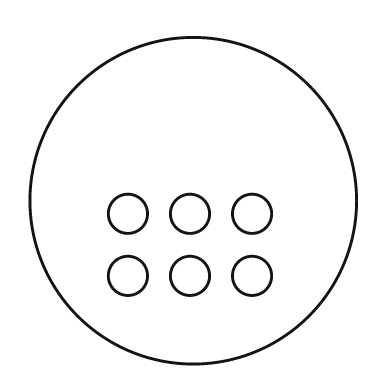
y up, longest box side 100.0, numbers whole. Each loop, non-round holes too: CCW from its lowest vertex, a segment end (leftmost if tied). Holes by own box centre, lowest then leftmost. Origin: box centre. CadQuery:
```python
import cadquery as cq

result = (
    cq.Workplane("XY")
    .moveTo(0.0, 0.0)
    .circle(50.0)
    .moveTo(-20.0, -23.0)
    .circle(6.0)
    .moveTo(-1.0, -23.0)
    .circle(6.0)
    .moveTo(18.0, -23.0)
    .circle(6.0)
    .moveTo(-20.0, -4.0)
    .circle(6.0)
    .moveTo(-1.0, -4.0)
    .circle(6.0)
    .moveTo(18.0, -4.0)
    .circle(6.0)
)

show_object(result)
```